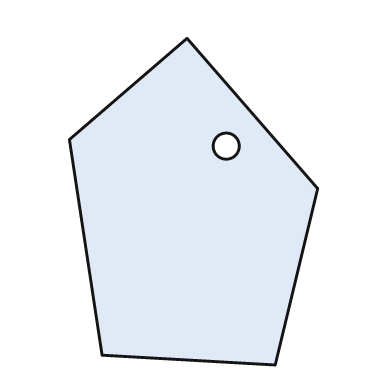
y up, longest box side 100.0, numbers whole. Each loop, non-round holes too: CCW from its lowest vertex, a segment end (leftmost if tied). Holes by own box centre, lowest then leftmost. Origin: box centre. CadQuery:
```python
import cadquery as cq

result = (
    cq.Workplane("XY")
    .moveTo(25.0, -50.0)
    .lineTo(38.0, 4.0)
    .lineTo(-2.0, 50.0)
    .lineTo(-38.0, 19.0)
    .lineTo(-28.0, -47.0)
    .close()
    .moveTo(10.0, 17.0)
    .circle(4.0)
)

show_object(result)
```